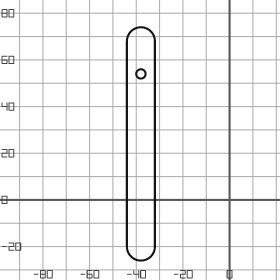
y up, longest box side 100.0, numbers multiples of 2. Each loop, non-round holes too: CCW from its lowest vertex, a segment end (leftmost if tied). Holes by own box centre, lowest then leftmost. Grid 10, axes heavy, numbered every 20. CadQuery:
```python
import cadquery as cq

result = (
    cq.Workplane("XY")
    .moveTo(-44.0, -20.0)
    .threePointArc((-38.0, -26.0), (-32.0, -20.0))
    .lineTo(-32.0, 68.0)
    .threePointArc((-38.0, 74.0), (-44.0, 68.0))
    .close()
    .moveTo(-38.0, 54.0)
    .circle(2.0)
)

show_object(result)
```